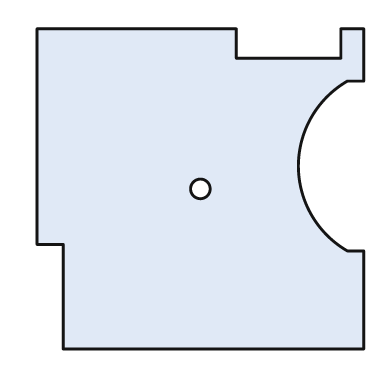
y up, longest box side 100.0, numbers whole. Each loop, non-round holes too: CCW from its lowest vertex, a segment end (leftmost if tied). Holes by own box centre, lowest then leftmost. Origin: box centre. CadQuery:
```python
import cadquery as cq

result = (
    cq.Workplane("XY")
    .moveTo(-42.0, -49.0)
    .lineTo(50.0, -49.0)
    .lineTo(50.0, -19.0)
    .lineTo(45.0, -19.0)
    .threePointArc((30.0, 7.0), (45.0, 33.0))
    .lineTo(50.0, 33.0)
    .lineTo(50.0, 49.0)
    .lineTo(43.0, 49.0)
    .lineTo(43.0, 40.0)
    .lineTo(11.0, 40.0)
    .lineTo(11.0, 49.0)
    .lineTo(-50.0, 49.0)
    .lineTo(-50.0, -17.0)
    .lineTo(-42.0, -17.0)
    .close()
    .moveTo(0.0, 0.0)
    .circle(3.0)
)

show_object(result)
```